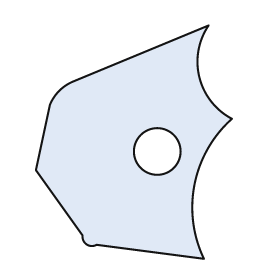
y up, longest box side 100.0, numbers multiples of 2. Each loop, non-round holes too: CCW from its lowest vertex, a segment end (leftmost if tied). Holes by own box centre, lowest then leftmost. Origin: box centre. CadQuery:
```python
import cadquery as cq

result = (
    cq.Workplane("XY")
    .moveTo(30.0, -50.0)
    .threePointArc((26.0, -18.0), (42.0, 10.0))
    .threePointArc((28.0, 28.0), (32.0, 50.0))
    .lineTo(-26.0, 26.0)
    .threePointArc((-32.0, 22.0), (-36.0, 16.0))
    .lineTo(-42.0, -12.0)
    .lineTo(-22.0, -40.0)
    .threePointArc((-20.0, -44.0), (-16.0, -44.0))
    .close()
    .moveTo(10.0, -4.0)
    .circle(10.0)
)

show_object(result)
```